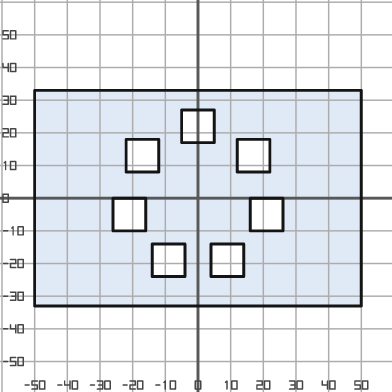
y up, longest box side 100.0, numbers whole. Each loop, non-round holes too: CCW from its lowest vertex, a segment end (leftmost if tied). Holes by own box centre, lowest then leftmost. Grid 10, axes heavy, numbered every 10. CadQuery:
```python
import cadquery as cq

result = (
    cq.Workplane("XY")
    .moveTo(-50.0, -33.0)
    .lineTo(50.0, -33.0)
    .lineTo(50.0, 33.0)
    .lineTo(-50.0, 33.0)
    .close()
    .moveTo(-14.0, -24.0)
    .lineTo(-4.0, -24.0)
    .lineTo(-4.0, -14.0)
    .lineTo(-14.0, -14.0)
    .close()
    .moveTo(4.0, -24.0)
    .lineTo(14.0, -24.0)
    .lineTo(14.0, -14.0)
    .lineTo(4.0, -14.0)
    .close()
    .moveTo(-26.0, -10.0)
    .lineTo(-16.0, -10.0)
    .lineTo(-16.0, 0.0)
    .lineTo(-26.0, 0.0)
    .close()
    .moveTo(16.0, -10.0)
    .lineTo(26.0, -10.0)
    .lineTo(26.0, 0.0)
    .lineTo(16.0, 0.0)
    .close()
    .moveTo(-22.0, 8.0)
    .lineTo(-12.0, 8.0)
    .lineTo(-12.0, 18.0)
    .lineTo(-22.0, 18.0)
    .close()
    .moveTo(12.0, 8.0)
    .lineTo(22.0, 8.0)
    .lineTo(22.0, 18.0)
    .lineTo(12.0, 18.0)
    .close()
    .moveTo(-5.0, 17.0)
    .lineTo(5.0, 17.0)
    .lineTo(5.0, 27.0)
    .lineTo(-5.0, 27.0)
    .close()
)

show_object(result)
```